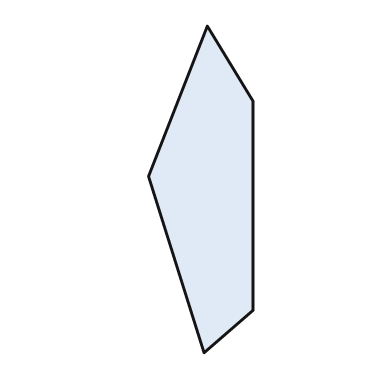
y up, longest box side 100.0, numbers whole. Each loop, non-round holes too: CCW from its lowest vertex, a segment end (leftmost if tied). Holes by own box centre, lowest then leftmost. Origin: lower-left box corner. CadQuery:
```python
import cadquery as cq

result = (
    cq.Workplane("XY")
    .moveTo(17.0, 0.0)
    .lineTo(32.0, 13.0)
    .lineTo(32.0, 77.0)
    .lineTo(18.0, 100.0)
    .lineTo(0.0, 54.0)
    .close()
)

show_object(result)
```